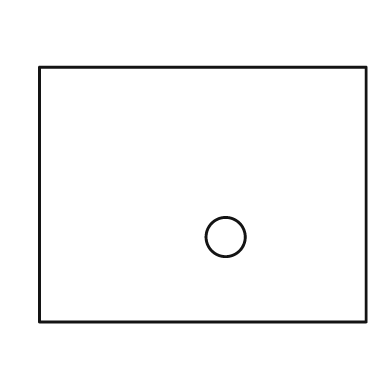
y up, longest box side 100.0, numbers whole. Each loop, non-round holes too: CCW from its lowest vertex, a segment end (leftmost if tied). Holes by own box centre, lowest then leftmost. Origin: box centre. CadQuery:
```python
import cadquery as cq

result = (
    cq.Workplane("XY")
    .moveTo(-50.0, -39.0)
    .lineTo(50.0, -39.0)
    .lineTo(50.0, 39.0)
    .lineTo(-50.0, 39.0)
    .close()
    .moveTo(7.0, -13.0)
    .circle(6.0)
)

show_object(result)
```